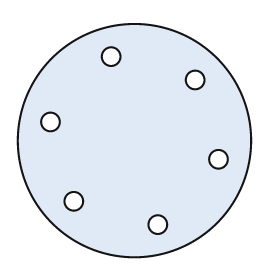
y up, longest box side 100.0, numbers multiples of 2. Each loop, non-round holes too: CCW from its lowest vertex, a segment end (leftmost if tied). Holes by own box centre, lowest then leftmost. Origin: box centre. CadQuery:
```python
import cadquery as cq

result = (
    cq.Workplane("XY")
    .moveTo(0.0, 0.0)
    .circle(50.0)
    .moveTo(10.0, -36.0)
    .circle(4.0)
    .moveTo(-26.0, -26.0)
    .circle(4.0)
    .moveTo(36.0, -8.0)
    .circle(4.0)
    .moveTo(-36.0, 8.0)
    .circle(4.0)
    .moveTo(26.0, 26.0)
    .circle(4.0)
    .moveTo(-10.0, 36.0)
    .circle(4.0)
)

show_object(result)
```